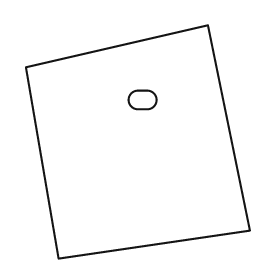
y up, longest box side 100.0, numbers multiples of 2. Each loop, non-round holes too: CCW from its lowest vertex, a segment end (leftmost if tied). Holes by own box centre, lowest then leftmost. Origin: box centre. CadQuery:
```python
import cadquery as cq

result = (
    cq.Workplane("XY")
    .moveTo(-34.0, -50.0)
    .lineTo(48.0, -38.0)
    .lineTo(30.0, 50.0)
    .lineTo(-48.0, 32.0)
    .close()
    .moveTo(0.0, 14.0)
    .lineTo(4.0, 14.0)
    .threePointArc((8.0, 18.0), (4.0, 22.0))
    .lineTo(0.0, 22.0)
    .threePointArc((-4.0, 18.0), (0.0, 14.0))
    .close()
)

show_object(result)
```